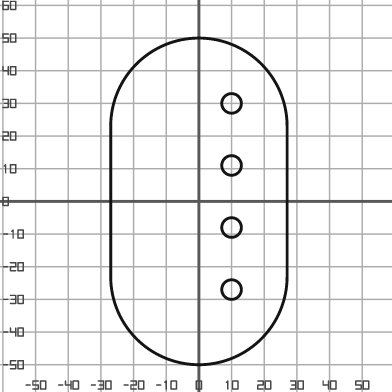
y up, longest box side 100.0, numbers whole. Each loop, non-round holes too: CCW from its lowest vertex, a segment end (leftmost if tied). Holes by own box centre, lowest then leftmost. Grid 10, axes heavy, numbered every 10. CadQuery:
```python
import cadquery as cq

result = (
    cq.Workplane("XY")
    .moveTo(-27.0, -23.0)
    .threePointArc((0.0, -50.0), (27.0, -23.0))
    .lineTo(27.0, 23.0)
    .threePointArc((0.0, 50.0), (-27.0, 23.0))
    .close()
    .moveTo(10.0, -27.0)
    .circle(3.0)
    .moveTo(10.0, -8.0)
    .circle(3.0)
    .moveTo(10.0, 11.0)
    .circle(3.0)
    .moveTo(10.0, 30.0)
    .circle(3.0)
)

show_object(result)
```